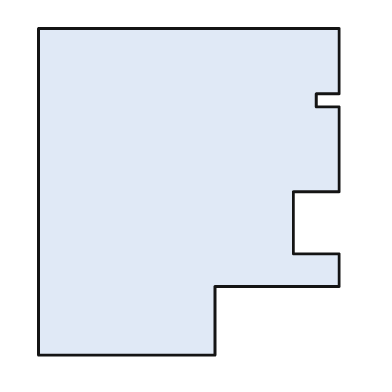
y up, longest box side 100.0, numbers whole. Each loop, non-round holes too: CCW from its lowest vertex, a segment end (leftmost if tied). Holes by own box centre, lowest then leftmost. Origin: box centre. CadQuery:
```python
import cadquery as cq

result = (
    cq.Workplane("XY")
    .moveTo(-46.0, -50.0)
    .lineTo(8.0, -50.0)
    .lineTo(8.0, -29.0)
    .lineTo(46.0, -29.0)
    .lineTo(46.0, -19.0)
    .lineTo(32.0, -19.0)
    .lineTo(32.0, 0.0)
    .lineTo(46.0, 0.0)
    .lineTo(46.0, 26.0)
    .lineTo(39.0, 26.0)
    .lineTo(39.0, 30.0)
    .lineTo(46.0, 30.0)
    .lineTo(46.0, 50.0)
    .lineTo(-46.0, 50.0)
    .close()
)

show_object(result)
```